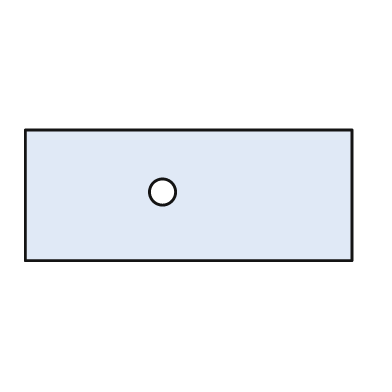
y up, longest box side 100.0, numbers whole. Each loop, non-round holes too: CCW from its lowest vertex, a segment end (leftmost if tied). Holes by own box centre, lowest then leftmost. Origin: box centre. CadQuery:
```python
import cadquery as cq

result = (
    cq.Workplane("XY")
    .moveTo(-50.0, -20.0)
    .lineTo(50.0, -20.0)
    .lineTo(50.0, 20.0)
    .lineTo(-50.0, 20.0)
    .close()
    .moveTo(-8.0, 1.0)
    .circle(4.0)
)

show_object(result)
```